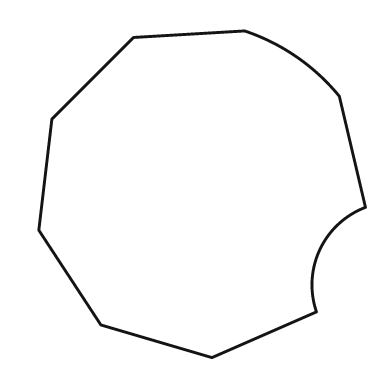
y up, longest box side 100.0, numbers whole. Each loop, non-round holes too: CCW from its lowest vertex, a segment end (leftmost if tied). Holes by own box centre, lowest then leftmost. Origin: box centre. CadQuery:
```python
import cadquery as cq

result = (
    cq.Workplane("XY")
    .moveTo(3.0, -50.0)
    .lineTo(35.0, -36.0)
    .threePointArc((36.0, -17.0), (50.0, -4.0))
    .lineTo(42.0, 30.0)
    .threePointArc((29.0, 42.0), (13.0, 50.0))
    .lineTo(-21.0, 48.0)
    .lineTo(-46.0, 23.0)
    .lineTo(-50.0, -11.0)
    .lineTo(-31.0, -40.0)
    .close()
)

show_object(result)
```